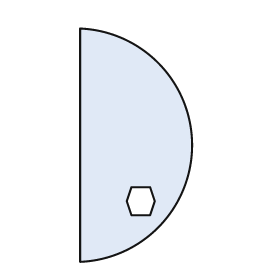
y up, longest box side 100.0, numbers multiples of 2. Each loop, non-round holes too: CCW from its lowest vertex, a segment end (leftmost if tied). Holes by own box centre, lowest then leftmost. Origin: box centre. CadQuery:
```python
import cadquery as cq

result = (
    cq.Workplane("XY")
    .moveTo(-24.0, -50.0)
    .threePointArc((24.0, 0.0), (-24.0, 50.0))
    .close()
    .moveTo(-2.0, -30.0)
    .lineTo(6.0, -30.0)
    .lineTo(8.0, -24.0)
    .lineTo(6.0, -18.0)
    .lineTo(-2.0, -18.0)
    .lineTo(-4.0, -24.0)
    .close()
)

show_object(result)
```